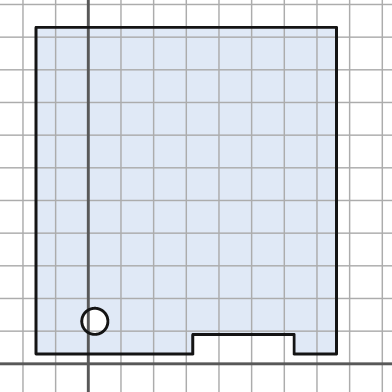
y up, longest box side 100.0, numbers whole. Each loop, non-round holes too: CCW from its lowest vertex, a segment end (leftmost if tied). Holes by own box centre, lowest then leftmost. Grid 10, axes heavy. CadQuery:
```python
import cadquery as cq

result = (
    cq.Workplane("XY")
    .moveTo(-16.0, 3.0)
    .lineTo(32.0, 3.0)
    .lineTo(32.0, 9.0)
    .lineTo(63.0, 9.0)
    .lineTo(63.0, 3.0)
    .lineTo(76.0, 3.0)
    .lineTo(76.0, 103.0)
    .lineTo(-16.0, 103.0)
    .close()
    .moveTo(2.0, 13.0)
    .circle(4.0)
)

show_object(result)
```